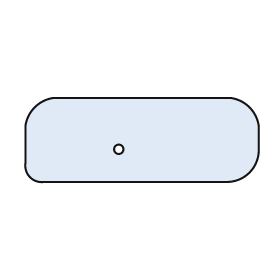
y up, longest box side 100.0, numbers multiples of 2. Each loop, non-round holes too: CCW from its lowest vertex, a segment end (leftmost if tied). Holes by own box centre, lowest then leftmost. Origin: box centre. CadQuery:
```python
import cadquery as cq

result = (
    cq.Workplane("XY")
    .moveTo(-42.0, -18.0)
    .lineTo(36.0, -18.0)
    .threePointArc((46.0, -14.0), (50.0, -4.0))
    .lineTo(50.0, 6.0)
    .threePointArc((46.0, 14.0), (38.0, 18.0))
    .lineTo(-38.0, 18.0)
    .threePointArc((-46.0, 14.0), (-50.0, 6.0))
    .lineTo(-50.0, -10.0)
    .threePointArc((-48.0, -16.0), (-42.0, -18.0))
    .close()
    .moveTo(-10.0, -4.0)
    .circle(2.0)
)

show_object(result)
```